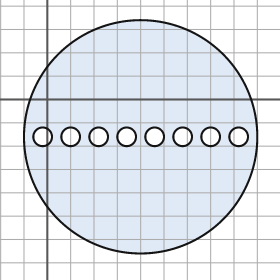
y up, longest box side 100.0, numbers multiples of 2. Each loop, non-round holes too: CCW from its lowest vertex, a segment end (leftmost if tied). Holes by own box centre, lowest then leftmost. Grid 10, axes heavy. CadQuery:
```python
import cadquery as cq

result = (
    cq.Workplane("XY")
    .moveTo(40.0, -16.0)
    .circle(50.0)
    .moveTo(-2.0, -16.0)
    .circle(4.0)
    .moveTo(10.0, -16.0)
    .circle(4.0)
    .moveTo(22.0, -16.0)
    .circle(4.0)
    .moveTo(34.0, -16.0)
    .circle(4.0)
    .moveTo(46.0, -16.0)
    .circle(4.0)
    .moveTo(58.0, -16.0)
    .circle(4.0)
    .moveTo(70.0, -16.0)
    .circle(4.0)
    .moveTo(82.0, -16.0)
    .circle(4.0)
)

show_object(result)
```